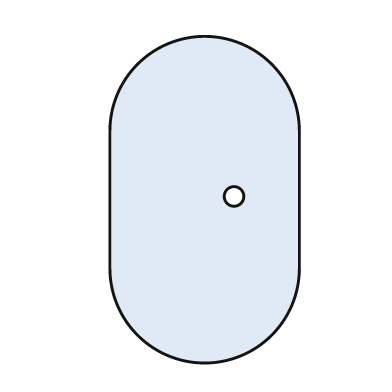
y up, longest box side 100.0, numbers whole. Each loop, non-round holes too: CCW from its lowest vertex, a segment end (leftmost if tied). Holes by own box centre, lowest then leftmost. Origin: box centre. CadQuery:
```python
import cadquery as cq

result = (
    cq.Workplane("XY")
    .moveTo(-29.0, -21.0)
    .threePointArc((0.0, -50.0), (29.0, -21.0))
    .lineTo(29.0, 21.0)
    .threePointArc((0.0, 50.0), (-29.0, 21.0))
    .close()
    .moveTo(9.0, 1.0)
    .circle(3.0)
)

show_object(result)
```